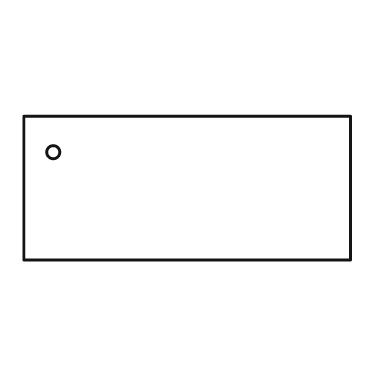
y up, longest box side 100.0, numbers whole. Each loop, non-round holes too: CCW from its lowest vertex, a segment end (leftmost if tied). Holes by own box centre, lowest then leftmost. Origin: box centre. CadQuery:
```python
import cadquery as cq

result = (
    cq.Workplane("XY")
    .moveTo(-50.0, -22.0)
    .lineTo(50.0, -22.0)
    .lineTo(50.0, 22.0)
    .lineTo(-50.0, 22.0)
    .close()
    .moveTo(-41.0, 11.0)
    .circle(2.0)
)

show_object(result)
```